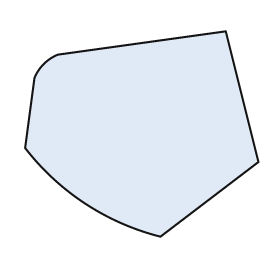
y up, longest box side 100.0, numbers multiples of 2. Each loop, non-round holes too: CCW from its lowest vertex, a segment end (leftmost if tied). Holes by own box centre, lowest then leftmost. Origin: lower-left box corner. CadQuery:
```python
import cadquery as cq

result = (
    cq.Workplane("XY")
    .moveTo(58.0, 0.0)
    .lineTo(100.0, 32.0)
    .lineTo(86.0, 88.0)
    .lineTo(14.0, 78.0)
    .threePointArc((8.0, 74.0), (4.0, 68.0))
    .lineTo(0.0, 38.0)
    .threePointArc((26.0, 14.0), (58.0, 0.0))
    .close()
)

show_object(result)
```